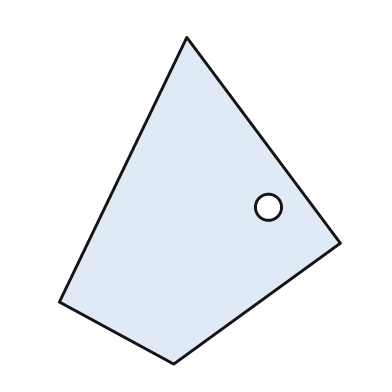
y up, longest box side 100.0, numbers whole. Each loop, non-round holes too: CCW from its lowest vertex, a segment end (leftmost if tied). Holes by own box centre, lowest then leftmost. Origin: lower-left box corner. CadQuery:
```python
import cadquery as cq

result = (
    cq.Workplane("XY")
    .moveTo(35.0, 0.0)
    .lineTo(86.0, 37.0)
    .lineTo(39.0, 100.0)
    .lineTo(0.0, 19.0)
    .close()
    .moveTo(64.0, 48.0)
    .circle(4.0)
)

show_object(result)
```